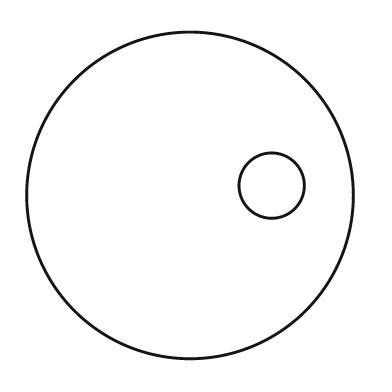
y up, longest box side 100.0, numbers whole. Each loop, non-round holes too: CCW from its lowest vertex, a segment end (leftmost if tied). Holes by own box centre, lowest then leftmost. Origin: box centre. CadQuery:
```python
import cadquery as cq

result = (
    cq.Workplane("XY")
    .moveTo(0.0, 0.0)
    .circle(50.0)
    .moveTo(25.0, 3.0)
    .circle(10.0)
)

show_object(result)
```